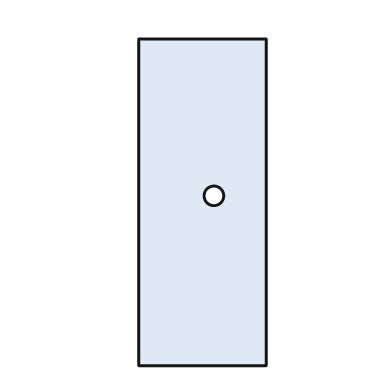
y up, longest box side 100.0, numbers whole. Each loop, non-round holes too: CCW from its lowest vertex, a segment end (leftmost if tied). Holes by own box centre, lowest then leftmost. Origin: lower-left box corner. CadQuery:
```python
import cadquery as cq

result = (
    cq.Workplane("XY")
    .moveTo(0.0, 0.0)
    .lineTo(39.0, 0.0)
    .lineTo(39.0, 100.0)
    .lineTo(0.0, 100.0)
    .close()
    .moveTo(23.0, 52.0)
    .circle(3.0)
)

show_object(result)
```